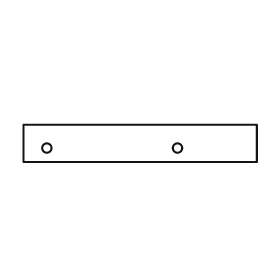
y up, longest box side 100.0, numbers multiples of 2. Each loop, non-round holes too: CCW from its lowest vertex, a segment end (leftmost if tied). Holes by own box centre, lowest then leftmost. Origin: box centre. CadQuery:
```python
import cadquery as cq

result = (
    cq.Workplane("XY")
    .moveTo(-50.0, -8.0)
    .lineTo(50.0, -8.0)
    .lineTo(50.0, 8.0)
    .lineTo(-50.0, 8.0)
    .close()
    .moveTo(-40.0, -2.0)
    .circle(2.0)
    .moveTo(16.0, -2.0)
    .circle(2.0)
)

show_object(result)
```